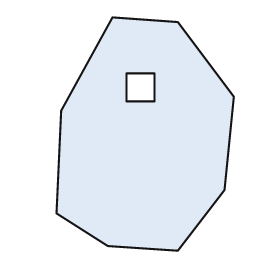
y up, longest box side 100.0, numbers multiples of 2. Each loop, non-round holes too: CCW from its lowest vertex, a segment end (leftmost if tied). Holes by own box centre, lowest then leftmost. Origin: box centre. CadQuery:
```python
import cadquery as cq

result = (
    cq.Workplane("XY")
    .moveTo(14.0, -50.0)
    .lineTo(34.0, -24.0)
    .lineTo(38.0, 16.0)
    .lineTo(14.0, 48.0)
    .lineTo(-14.0, 50.0)
    .lineTo(-36.0, 10.0)
    .lineTo(-38.0, -34.0)
    .lineTo(-16.0, -48.0)
    .close()
    .moveTo(-8.0, 14.0)
    .lineTo(4.0, 14.0)
    .lineTo(4.0, 26.0)
    .lineTo(-8.0, 26.0)
    .close()
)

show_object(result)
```